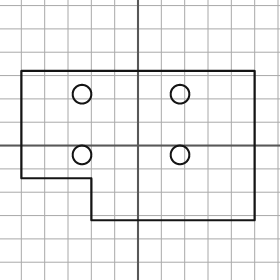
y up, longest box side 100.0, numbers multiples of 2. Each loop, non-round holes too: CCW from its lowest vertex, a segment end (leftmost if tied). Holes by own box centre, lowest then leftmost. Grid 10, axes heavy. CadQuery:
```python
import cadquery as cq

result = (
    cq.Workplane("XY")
    .moveTo(-20.0, -32.0)
    .lineTo(50.0, -32.0)
    .lineTo(50.0, 32.0)
    .lineTo(-50.0, 32.0)
    .lineTo(-50.0, -14.0)
    .lineTo(-20.0, -14.0)
    .close()
    .moveTo(-24.0, -4.0)
    .circle(4.0)
    .moveTo(18.0, -4.0)
    .circle(4.0)
    .moveTo(-24.0, 22.0)
    .circle(4.0)
    .moveTo(18.0, 22.0)
    .circle(4.0)
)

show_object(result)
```